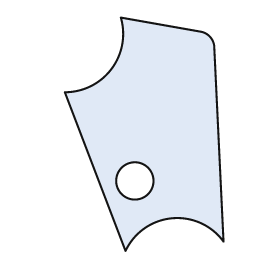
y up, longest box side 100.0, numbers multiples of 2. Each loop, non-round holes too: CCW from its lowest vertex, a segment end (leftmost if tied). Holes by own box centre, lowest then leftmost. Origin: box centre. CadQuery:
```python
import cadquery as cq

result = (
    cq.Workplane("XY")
    .moveTo(-8.0, -50.0)
    .threePointArc((12.0, -36.0), (34.0, -46.0))
    .lineTo(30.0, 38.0)
    .threePointArc((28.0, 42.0), (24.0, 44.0))
    .lineTo(-10.0, 50.0)
    .threePointArc((-14.0, 28.0), (-34.0, 18.0))
    .close()
    .moveTo(-4.0, -20.0)
    .circle(8.0)
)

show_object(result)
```